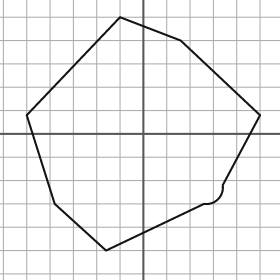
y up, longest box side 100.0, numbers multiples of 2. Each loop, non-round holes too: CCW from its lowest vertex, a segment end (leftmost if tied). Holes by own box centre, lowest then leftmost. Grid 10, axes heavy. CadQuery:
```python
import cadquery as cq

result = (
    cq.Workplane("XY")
    .moveTo(-16.0, -50.0)
    .lineTo(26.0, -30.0)
    .threePointArc((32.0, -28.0), (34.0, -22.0))
    .lineTo(50.0, 8.0)
    .lineTo(16.0, 40.0)
    .lineTo(-10.0, 50.0)
    .lineTo(-50.0, 8.0)
    .lineTo(-38.0, -30.0)
    .close()
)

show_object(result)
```